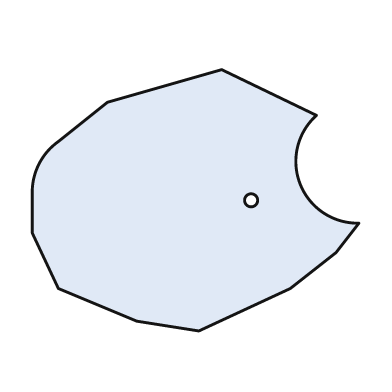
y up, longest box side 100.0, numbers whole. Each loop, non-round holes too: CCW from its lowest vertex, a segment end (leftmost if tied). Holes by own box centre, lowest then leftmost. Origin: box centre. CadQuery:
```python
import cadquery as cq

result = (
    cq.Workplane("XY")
    .moveTo(1.0, -40.0)
    .lineTo(29.0, -27.0)
    .lineTo(43.0, -16.0)
    .lineTo(50.0, -7.0)
    .threePointArc((32.0, 5.0), (37.0, 26.0))
    .lineTo(8.0, 40.0)
    .lineTo(-27.0, 30.0)
    .lineTo(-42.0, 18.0)
    .threePointArc((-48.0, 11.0), (-50.0, 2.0))
    .lineTo(-50.0, -10.0)
    .lineTo(-42.0, -27.0)
    .lineTo(-18.0, -37.0)
    .close()
    .moveTo(17.0, 0.0)
    .circle(2.0)
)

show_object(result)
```